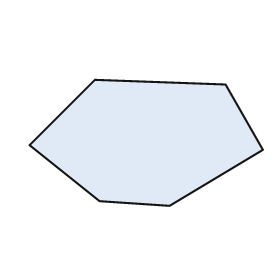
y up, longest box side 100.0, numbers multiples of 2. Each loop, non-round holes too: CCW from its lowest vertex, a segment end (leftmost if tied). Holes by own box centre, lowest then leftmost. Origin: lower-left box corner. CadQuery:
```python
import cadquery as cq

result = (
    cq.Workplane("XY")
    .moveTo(60.0, 0.0)
    .lineTo(100.0, 24.0)
    .lineTo(84.0, 52.0)
    .lineTo(28.0, 54.0)
    .lineTo(0.0, 26.0)
    .lineTo(30.0, 2.0)
    .close()
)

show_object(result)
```